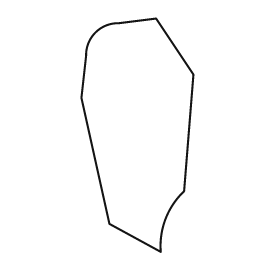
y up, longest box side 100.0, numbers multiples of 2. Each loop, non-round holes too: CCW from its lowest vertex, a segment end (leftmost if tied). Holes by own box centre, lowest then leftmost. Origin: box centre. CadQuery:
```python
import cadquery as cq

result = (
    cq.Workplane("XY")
    .moveTo(10.0, -50.0)
    .threePointArc((12.0, -36.0), (20.0, -24.0))
    .lineTo(24.0, 26.0)
    .lineTo(8.0, 50.0)
    .lineTo(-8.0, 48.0)
    .threePointArc((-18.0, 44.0), (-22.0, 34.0))
    .lineTo(-24.0, 16.0)
    .lineTo(-12.0, -38.0)
    .close()
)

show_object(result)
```